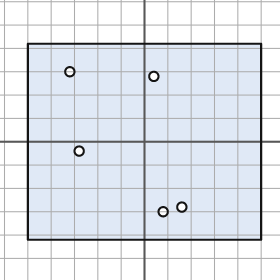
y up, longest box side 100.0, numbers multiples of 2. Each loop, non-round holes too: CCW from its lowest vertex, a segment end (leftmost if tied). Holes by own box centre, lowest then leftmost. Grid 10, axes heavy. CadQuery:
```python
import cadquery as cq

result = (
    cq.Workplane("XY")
    .moveTo(-50.0, -42.0)
    .lineTo(50.0, -42.0)
    .lineTo(50.0, 42.0)
    .lineTo(-50.0, 42.0)
    .close()
    .moveTo(8.0, -30.0)
    .circle(2.0)
    .moveTo(16.0, -28.0)
    .circle(2.0)
    .moveTo(-28.0, -4.0)
    .circle(2.0)
    .moveTo(4.0, 28.0)
    .circle(2.0)
    .moveTo(-32.0, 30.0)
    .circle(2.0)
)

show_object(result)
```